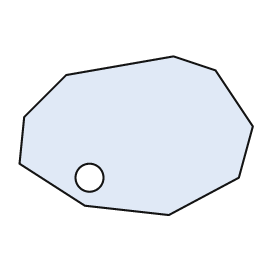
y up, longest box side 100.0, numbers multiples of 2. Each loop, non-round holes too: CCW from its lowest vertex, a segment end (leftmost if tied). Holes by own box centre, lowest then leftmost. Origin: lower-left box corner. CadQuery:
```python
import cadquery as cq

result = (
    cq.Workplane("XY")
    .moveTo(64.0, 0.0)
    .lineTo(94.0, 16.0)
    .lineTo(100.0, 38.0)
    .lineTo(84.0, 62.0)
    .lineTo(66.0, 68.0)
    .lineTo(20.0, 60.0)
    .lineTo(2.0, 42.0)
    .lineTo(0.0, 22.0)
    .lineTo(28.0, 4.0)
    .close()
    .moveTo(30.0, 16.0)
    .circle(6.0)
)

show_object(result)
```